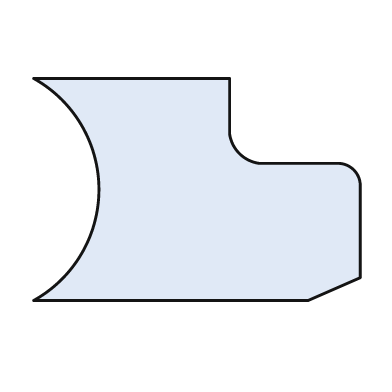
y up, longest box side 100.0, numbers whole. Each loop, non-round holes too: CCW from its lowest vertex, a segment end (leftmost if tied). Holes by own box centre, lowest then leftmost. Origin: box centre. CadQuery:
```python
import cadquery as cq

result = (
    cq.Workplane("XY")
    .moveTo(-50.0, -34.0)
    .lineTo(34.0, -34.0)
    .lineTo(50.0, -27.0)
    .lineTo(50.0, 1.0)
    .threePointArc((48.0, 6.0), (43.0, 8.0))
    .lineTo(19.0, 8.0)
    .threePointArc((13.0, 11.0), (10.0, 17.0))
    .lineTo(10.0, 34.0)
    .lineTo(-50.0, 34.0)
    .threePointArc((-30.0, 0.0), (-50.0, -34.0))
    .close()
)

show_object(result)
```